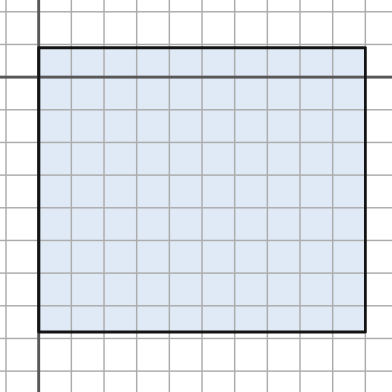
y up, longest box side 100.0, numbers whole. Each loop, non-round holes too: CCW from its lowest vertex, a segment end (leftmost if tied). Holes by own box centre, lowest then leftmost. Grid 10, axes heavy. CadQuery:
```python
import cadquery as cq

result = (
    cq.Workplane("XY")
    .moveTo(0.0, -78.0)
    .lineTo(100.0, -78.0)
    .lineTo(100.0, 9.0)
    .lineTo(0.0, 9.0)
    .close()
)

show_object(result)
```